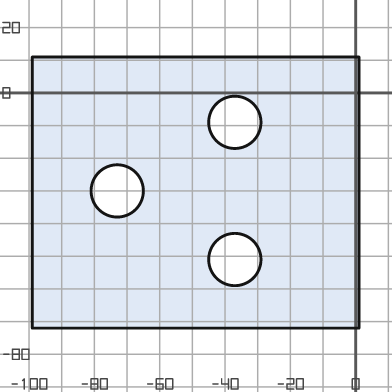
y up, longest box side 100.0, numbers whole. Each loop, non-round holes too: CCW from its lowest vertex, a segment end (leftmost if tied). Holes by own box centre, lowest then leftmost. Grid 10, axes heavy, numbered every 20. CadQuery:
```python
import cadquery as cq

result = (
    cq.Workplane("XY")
    .moveTo(-99.0, -72.0)
    .lineTo(1.0, -72.0)
    .lineTo(1.0, 11.0)
    .lineTo(-99.0, 11.0)
    .close()
    .moveTo(-37.0, -51.0)
    .circle(8.0)
    .moveTo(-73.0, -30.0)
    .circle(8.0)
    .moveTo(-37.0, -9.0)
    .circle(8.0)
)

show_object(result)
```